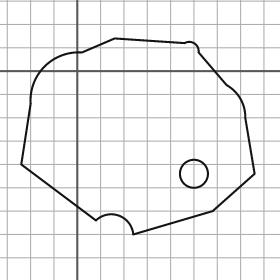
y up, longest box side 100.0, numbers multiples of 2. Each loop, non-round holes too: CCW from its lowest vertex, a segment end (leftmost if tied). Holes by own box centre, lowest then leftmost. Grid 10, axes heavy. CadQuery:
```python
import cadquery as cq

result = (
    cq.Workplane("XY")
    .moveTo(24.0, -70.0)
    .lineTo(58.0, -60.0)
    .lineTo(76.0, -44.0)
    .lineTo(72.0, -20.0)
    .threePointArc((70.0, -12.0), (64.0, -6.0))
    .lineTo(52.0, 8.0)
    .threePointArc((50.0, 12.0), (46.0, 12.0))
    .lineTo(16.0, 14.0)
    .lineTo(2.0, 8.0)
    .threePointArc((-14.0, 2.0), (-20.0, -14.0))
    .lineTo(-24.0, -40.0)
    .lineTo(8.0, -64.0)
    .threePointArc((18.0, -62.0), (24.0, -70.0))
    .close()
    .moveTo(50.0, -44.0)
    .circle(6.0)
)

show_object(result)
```